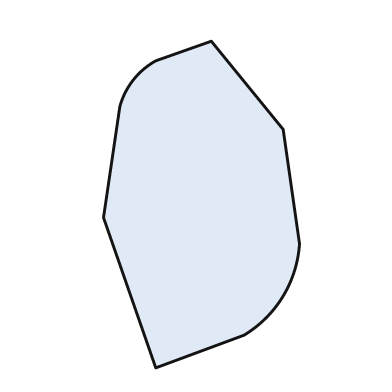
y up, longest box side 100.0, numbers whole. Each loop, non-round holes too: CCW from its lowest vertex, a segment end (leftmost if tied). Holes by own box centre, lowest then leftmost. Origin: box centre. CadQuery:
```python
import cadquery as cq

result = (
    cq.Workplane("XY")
    .moveTo(-14.0, -50.0)
    .lineTo(13.0, -40.0)
    .threePointArc((25.0, -28.0), (30.0, -12.0))
    .lineTo(25.0, 23.0)
    .lineTo(3.0, 50.0)
    .lineTo(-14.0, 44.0)
    .threePointArc((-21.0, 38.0), (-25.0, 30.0))
    .lineTo(-30.0, -4.0)
    .close()
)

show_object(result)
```